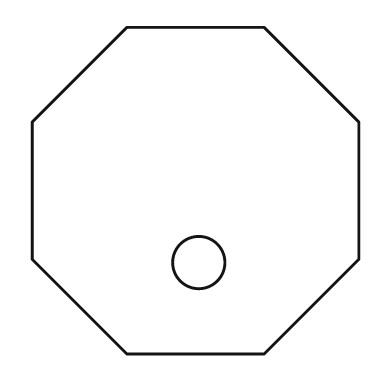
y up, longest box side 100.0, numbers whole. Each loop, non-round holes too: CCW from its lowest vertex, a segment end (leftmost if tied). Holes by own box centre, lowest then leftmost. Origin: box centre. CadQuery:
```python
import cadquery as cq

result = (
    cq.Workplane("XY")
    .moveTo(-21.0, -50.0)
    .lineTo(21.0, -50.0)
    .lineTo(50.0, -21.0)
    .lineTo(50.0, 21.0)
    .lineTo(21.0, 50.0)
    .lineTo(-21.0, 50.0)
    .lineTo(-50.0, 21.0)
    .lineTo(-50.0, -21.0)
    .close()
    .moveTo(1.0, -22.0)
    .circle(8.0)
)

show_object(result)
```